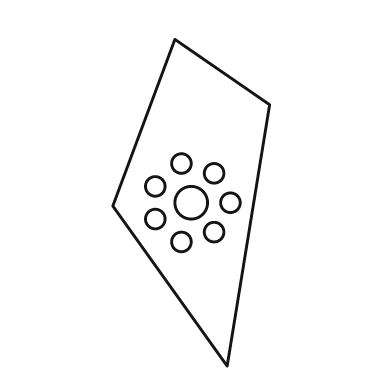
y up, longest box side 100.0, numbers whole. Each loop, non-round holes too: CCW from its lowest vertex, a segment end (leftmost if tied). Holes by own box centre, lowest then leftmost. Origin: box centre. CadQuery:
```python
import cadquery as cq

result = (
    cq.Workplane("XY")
    .moveTo(11.0, -50.0)
    .lineTo(24.0, 30.0)
    .lineTo(-5.0, 50.0)
    .lineTo(-24.0, -1.0)
    .close()
    .moveTo(-3.0, -12.0)
    .circle(3.0)
    .moveTo(7.0, -9.0)
    .circle(3.0)
    .moveTo(-11.0, -5.0)
    .circle(3.0)
    .moveTo(0.0, 0.0)
    .circle(5.0)
    .moveTo(12.0, 0.0)
    .circle(3.0)
    .moveTo(-11.0, 5.0)
    .circle(3.0)
    .moveTo(7.0, 9.0)
    .circle(3.0)
    .moveTo(-3.0, 12.0)
    .circle(3.0)
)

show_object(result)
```